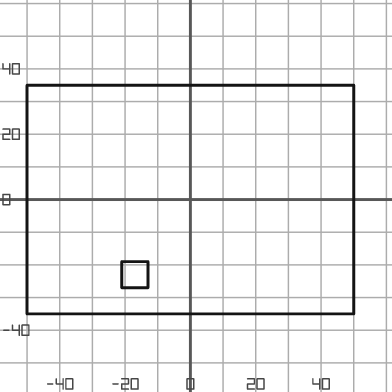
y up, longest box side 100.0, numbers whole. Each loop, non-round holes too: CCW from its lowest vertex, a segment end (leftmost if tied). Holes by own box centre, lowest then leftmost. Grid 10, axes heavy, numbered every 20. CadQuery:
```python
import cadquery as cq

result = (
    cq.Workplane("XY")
    .moveTo(-50.0, -35.0)
    .lineTo(50.0, -35.0)
    .lineTo(50.0, 35.0)
    .lineTo(-50.0, 35.0)
    .close()
    .moveTo(-21.0, -27.0)
    .lineTo(-13.0, -27.0)
    .lineTo(-13.0, -19.0)
    .lineTo(-21.0, -19.0)
    .close()
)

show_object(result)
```